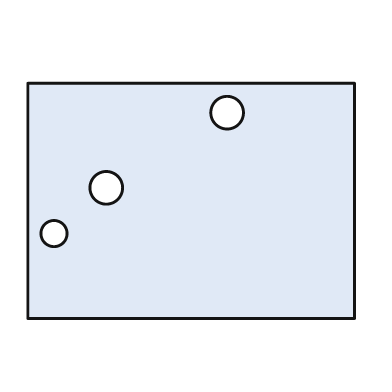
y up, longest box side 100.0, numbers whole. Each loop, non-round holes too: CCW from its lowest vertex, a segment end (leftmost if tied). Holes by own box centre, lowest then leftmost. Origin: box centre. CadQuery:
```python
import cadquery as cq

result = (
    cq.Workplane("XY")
    .moveTo(-50.0, -36.0)
    .lineTo(50.0, -36.0)
    .lineTo(50.0, 36.0)
    .lineTo(-50.0, 36.0)
    .close()
    .moveTo(-42.0, -10.0)
    .circle(4.0)
    .moveTo(-26.0, 4.0)
    .circle(5.0)
    .moveTo(11.0, 27.0)
    .circle(5.0)
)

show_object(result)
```